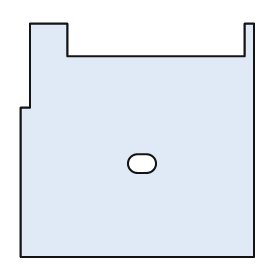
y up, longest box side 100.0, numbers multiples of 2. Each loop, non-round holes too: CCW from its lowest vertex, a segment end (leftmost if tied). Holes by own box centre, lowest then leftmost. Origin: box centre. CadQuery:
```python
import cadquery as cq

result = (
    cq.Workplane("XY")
    .moveTo(-50.0, -50.0)
    .lineTo(50.0, -50.0)
    .lineTo(50.0, 50.0)
    .lineTo(46.0, 50.0)
    .lineTo(46.0, 36.0)
    .lineTo(-30.0, 36.0)
    .lineTo(-30.0, 50.0)
    .lineTo(-46.0, 50.0)
    .lineTo(-46.0, 14.0)
    .lineTo(-50.0, 14.0)
    .close()
    .moveTo(0.0, -14.0)
    .lineTo(4.0, -14.0)
    .threePointArc((8.0, -10.0), (4.0, -6.0))
    .lineTo(0.0, -6.0)
    .threePointArc((-4.0, -10.0), (0.0, -14.0))
    .close()
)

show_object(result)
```